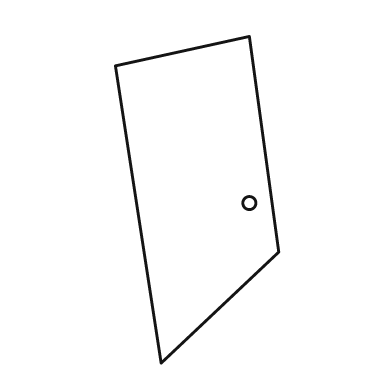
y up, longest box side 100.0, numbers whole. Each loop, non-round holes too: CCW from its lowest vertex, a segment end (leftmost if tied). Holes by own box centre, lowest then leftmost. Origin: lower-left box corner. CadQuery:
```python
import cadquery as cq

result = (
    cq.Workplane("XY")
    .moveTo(14.0, 0.0)
    .lineTo(50.0, 34.0)
    .lineTo(41.0, 100.0)
    .lineTo(0.0, 91.0)
    .close()
    .moveTo(41.0, 49.0)
    .circle(2.0)
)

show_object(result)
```